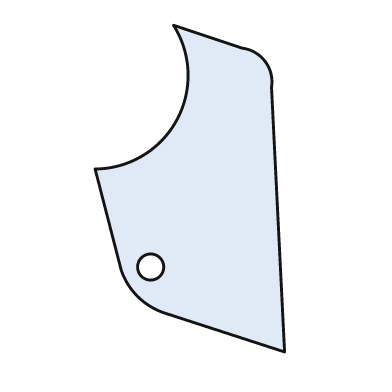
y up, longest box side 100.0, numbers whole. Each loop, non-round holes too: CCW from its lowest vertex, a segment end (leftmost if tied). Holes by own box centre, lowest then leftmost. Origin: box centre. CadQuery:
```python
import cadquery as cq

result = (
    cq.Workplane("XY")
    .moveTo(29.0, -50.0)
    .lineTo(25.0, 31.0)
    .threePointArc((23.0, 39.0), (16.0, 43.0))
    .lineTo(-5.0, 50.0)
    .threePointArc((-4.0, 21.0), (-29.0, 6.0))
    .lineTo(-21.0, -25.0)
    .threePointArc((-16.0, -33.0), (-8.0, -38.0))
    .close()
    .moveTo(-12.0, -24.0)
    .circle(4.0)
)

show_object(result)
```